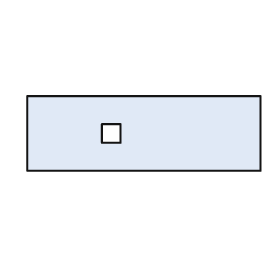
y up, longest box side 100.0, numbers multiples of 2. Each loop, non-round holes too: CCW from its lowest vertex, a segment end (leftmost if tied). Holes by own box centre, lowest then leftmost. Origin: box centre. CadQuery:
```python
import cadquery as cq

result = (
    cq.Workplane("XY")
    .moveTo(-50.0, -16.0)
    .lineTo(50.0, -16.0)
    .lineTo(50.0, 16.0)
    .lineTo(-50.0, 16.0)
    .close()
    .moveTo(-18.0, -4.0)
    .lineTo(-10.0, -4.0)
    .lineTo(-10.0, 4.0)
    .lineTo(-18.0, 4.0)
    .close()
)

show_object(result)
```